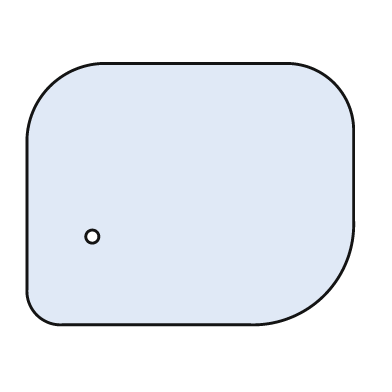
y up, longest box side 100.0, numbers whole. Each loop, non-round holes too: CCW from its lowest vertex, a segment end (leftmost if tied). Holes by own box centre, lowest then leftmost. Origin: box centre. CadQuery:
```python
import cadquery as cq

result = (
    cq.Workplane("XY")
    .moveTo(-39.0, -40.0)
    .lineTo(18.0, -40.0)
    .threePointArc((41.0, -31.0), (50.0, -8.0))
    .lineTo(50.0, 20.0)
    .threePointArc((44.0, 34.0), (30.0, 40.0))
    .lineTo(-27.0, 40.0)
    .threePointArc((-43.0, 33.0), (-50.0, 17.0))
    .lineTo(-50.0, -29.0)
    .threePointArc((-47.0, -37.0), (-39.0, -40.0))
    .close()
    .moveTo(-30.0, -13.0)
    .circle(2.0)
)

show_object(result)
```